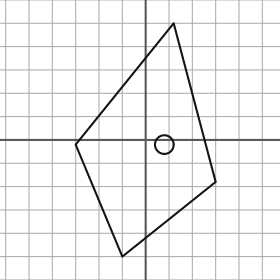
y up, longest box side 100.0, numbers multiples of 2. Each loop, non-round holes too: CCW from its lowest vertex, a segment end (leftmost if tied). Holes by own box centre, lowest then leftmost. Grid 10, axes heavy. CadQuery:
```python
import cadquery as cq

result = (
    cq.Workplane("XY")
    .moveTo(-10.0, -50.0)
    .lineTo(30.0, -18.0)
    .lineTo(12.0, 50.0)
    .lineTo(-30.0, -2.0)
    .close()
    .moveTo(8.0, -2.0)
    .circle(4.0)
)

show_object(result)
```